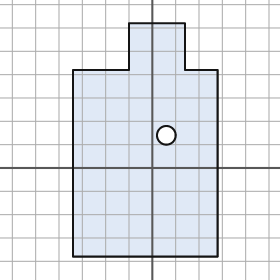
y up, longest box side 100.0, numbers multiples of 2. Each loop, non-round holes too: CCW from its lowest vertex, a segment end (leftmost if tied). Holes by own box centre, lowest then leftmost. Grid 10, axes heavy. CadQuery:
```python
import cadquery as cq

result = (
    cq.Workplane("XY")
    .moveTo(-34.0, -38.0)
    .lineTo(28.0, -38.0)
    .lineTo(28.0, 42.0)
    .lineTo(14.0, 42.0)
    .lineTo(14.0, 62.0)
    .lineTo(-10.0, 62.0)
    .lineTo(-10.0, 42.0)
    .lineTo(-34.0, 42.0)
    .close()
    .moveTo(6.0, 14.0)
    .circle(4.0)
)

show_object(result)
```